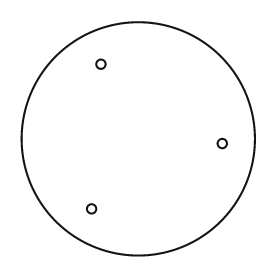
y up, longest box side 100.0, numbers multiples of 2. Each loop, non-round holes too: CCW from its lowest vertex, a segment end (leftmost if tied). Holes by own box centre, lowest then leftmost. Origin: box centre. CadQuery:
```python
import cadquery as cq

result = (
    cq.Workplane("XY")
    .moveTo(0.0, 0.0)
    .circle(50.0)
    .moveTo(-20.0, -30.0)
    .circle(2.0)
    .moveTo(36.0, -2.0)
    .circle(2.0)
    .moveTo(-16.0, 32.0)
    .circle(2.0)
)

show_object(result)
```